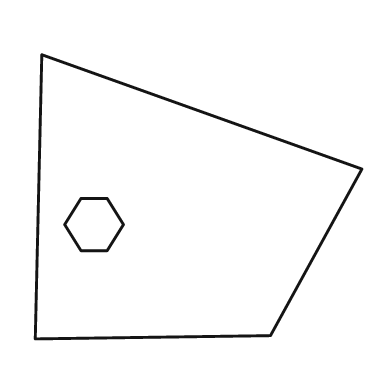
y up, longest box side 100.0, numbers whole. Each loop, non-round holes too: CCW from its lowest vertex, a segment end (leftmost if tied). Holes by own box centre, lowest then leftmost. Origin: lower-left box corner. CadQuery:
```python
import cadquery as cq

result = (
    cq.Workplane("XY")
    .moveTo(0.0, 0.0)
    .lineTo(72.0, 1.0)
    .lineTo(100.0, 52.0)
    .lineTo(2.0, 87.0)
    .close()
    .moveTo(14.0, 27.0)
    .lineTo(22.0, 27.0)
    .lineTo(27.0, 35.0)
    .lineTo(22.0, 43.0)
    .lineTo(14.0, 43.0)
    .lineTo(9.0, 35.0)
    .close()
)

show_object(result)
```